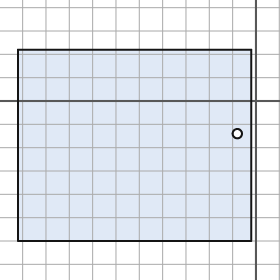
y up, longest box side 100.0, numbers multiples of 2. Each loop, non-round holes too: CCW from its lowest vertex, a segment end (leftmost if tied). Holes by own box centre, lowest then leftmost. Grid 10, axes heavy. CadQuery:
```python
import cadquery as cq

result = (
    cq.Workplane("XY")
    .moveTo(-102.0, -60.0)
    .lineTo(-2.0, -60.0)
    .lineTo(-2.0, 22.0)
    .lineTo(-102.0, 22.0)
    .close()
    .moveTo(-8.0, -14.0)
    .circle(2.0)
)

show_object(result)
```